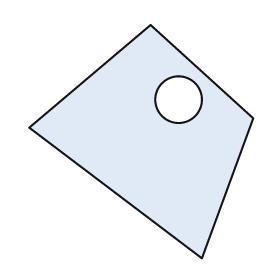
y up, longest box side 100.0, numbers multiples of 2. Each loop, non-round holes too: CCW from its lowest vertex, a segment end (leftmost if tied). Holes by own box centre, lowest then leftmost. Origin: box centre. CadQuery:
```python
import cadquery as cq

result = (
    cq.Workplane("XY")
    .moveTo(26.0, -50.0)
    .lineTo(48.0, 10.0)
    .lineTo(4.0, 50.0)
    .lineTo(-48.0, 6.0)
    .close()
    .moveTo(16.0, 18.0)
    .circle(10.0)
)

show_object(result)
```